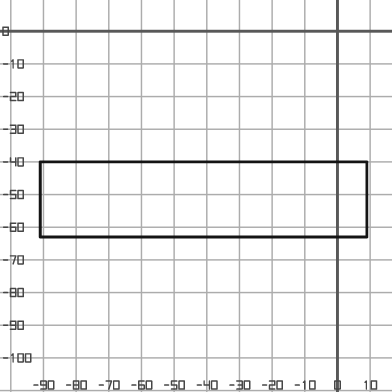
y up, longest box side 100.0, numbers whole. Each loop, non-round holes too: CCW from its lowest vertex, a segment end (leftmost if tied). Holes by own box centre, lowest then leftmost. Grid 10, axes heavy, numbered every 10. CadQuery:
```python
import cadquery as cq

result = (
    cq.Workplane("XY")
    .moveTo(-91.0, -63.0)
    .lineTo(9.0, -63.0)
    .lineTo(9.0, -40.0)
    .lineTo(-91.0, -40.0)
    .close()
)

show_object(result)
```